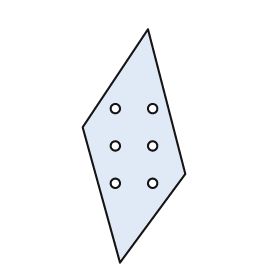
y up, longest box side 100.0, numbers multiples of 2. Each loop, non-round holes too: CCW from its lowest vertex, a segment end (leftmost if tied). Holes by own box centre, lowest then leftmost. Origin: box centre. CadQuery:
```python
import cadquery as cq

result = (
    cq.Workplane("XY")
    .moveTo(-6.0, -50.0)
    .lineTo(22.0, -12.0)
    .lineTo(6.0, 50.0)
    .lineTo(-22.0, 8.0)
    .close()
    .moveTo(-8.0, -16.0)
    .circle(2.0)
    .moveTo(8.0, -16.0)
    .circle(2.0)
    .moveTo(-8.0, 0.0)
    .circle(2.0)
    .moveTo(8.0, 0.0)
    .circle(2.0)
    .moveTo(-8.0, 16.0)
    .circle(2.0)
    .moveTo(8.0, 16.0)
    .circle(2.0)
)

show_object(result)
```